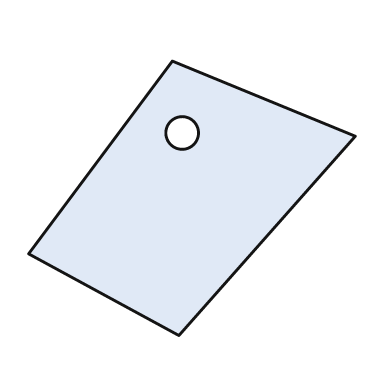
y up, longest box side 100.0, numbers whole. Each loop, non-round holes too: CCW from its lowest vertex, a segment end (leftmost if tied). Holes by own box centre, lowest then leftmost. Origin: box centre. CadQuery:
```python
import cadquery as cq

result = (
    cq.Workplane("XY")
    .moveTo(-4.0, -42.0)
    .lineTo(50.0, 19.0)
    .lineTo(-6.0, 42.0)
    .lineTo(-50.0, -17.0)
    .close()
    .moveTo(-3.0, 20.0)
    .circle(5.0)
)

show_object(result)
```